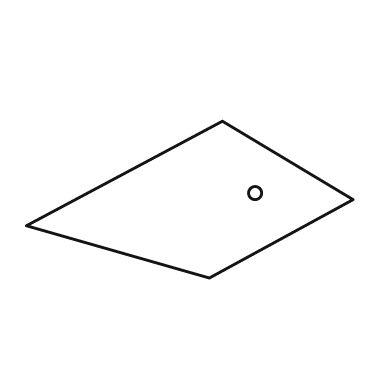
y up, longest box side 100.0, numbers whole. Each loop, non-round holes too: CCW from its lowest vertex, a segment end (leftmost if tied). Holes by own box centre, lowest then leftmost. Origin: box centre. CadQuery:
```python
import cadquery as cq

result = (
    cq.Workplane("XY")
    .moveTo(6.0, -24.0)
    .lineTo(50.0, 0.0)
    .lineTo(10.0, 24.0)
    .lineTo(-50.0, -8.0)
    .close()
    .moveTo(20.0, 2.0)
    .circle(2.0)
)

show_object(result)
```